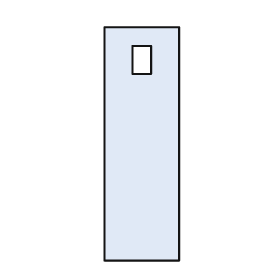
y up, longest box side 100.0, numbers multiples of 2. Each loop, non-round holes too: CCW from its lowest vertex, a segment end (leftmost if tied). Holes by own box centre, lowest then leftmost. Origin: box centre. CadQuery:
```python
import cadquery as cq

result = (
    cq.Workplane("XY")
    .moveTo(-16.0, -50.0)
    .lineTo(16.0, -50.0)
    .lineTo(16.0, 50.0)
    .lineTo(-16.0, 50.0)
    .close()
    .moveTo(-4.0, 30.0)
    .lineTo(4.0, 30.0)
    .lineTo(4.0, 42.0)
    .lineTo(-4.0, 42.0)
    .close()
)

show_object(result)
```